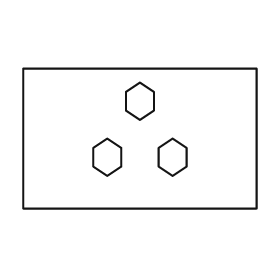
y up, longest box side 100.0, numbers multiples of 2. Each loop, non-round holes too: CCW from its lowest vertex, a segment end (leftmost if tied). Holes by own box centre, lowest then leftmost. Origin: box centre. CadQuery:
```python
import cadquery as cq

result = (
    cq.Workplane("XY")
    .moveTo(-50.0, -30.0)
    .lineTo(50.0, -30.0)
    .lineTo(50.0, 30.0)
    .lineTo(-50.0, 30.0)
    .close()
    .moveTo(-14.0, -16.0)
    .lineTo(-8.0, -12.0)
    .lineTo(-8.0, -4.0)
    .lineTo(-14.0, 0.0)
    .lineTo(-20.0, -4.0)
    .lineTo(-20.0, -12.0)
    .close()
    .moveTo(14.0, -16.0)
    .lineTo(20.0, -12.0)
    .lineTo(20.0, -4.0)
    .lineTo(14.0, 0.0)
    .lineTo(8.0, -4.0)
    .lineTo(8.0, -12.0)
    .close()
    .moveTo(0.0, 8.0)
    .lineTo(6.0, 12.0)
    .lineTo(6.0, 20.0)
    .lineTo(0.0, 24.0)
    .lineTo(-6.0, 20.0)
    .lineTo(-6.0, 12.0)
    .close()
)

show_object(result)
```